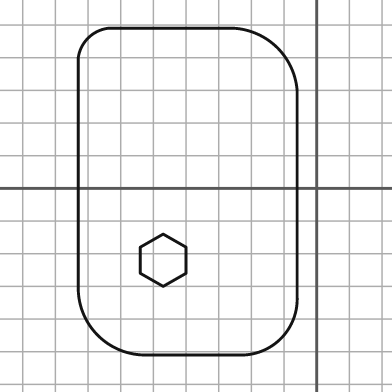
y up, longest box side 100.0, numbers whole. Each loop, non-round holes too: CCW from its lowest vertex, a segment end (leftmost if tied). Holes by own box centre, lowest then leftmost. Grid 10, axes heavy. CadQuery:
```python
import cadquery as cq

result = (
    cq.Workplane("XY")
    .moveTo(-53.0, -51.0)
    .lineTo(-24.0, -51.0)
    .threePointArc((-11.0, -46.0), (-6.0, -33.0))
    .lineTo(-6.0, 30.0)
    .threePointArc((-12.0, 43.0), (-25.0, 49.0))
    .lineTo(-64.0, 49.0)
    .threePointArc((-70.0, 46.0), (-73.0, 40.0))
    .lineTo(-73.0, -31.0)
    .threePointArc((-67.0, -45.0), (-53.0, -51.0))
    .close()
    .moveTo(-47.0, -30.0)
    .lineTo(-40.0, -26.0)
    .lineTo(-40.0, -18.0)
    .lineTo(-47.0, -14.0)
    .lineTo(-54.0, -18.0)
    .lineTo(-54.0, -26.0)
    .close()
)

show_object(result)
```